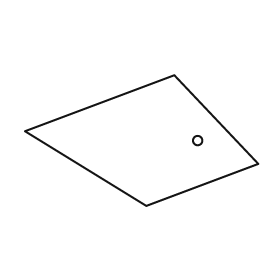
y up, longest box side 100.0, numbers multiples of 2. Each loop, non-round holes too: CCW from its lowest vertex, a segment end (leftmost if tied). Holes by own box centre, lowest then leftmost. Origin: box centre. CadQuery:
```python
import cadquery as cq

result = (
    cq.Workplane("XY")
    .moveTo(2.0, -28.0)
    .lineTo(50.0, -10.0)
    .lineTo(14.0, 28.0)
    .lineTo(-50.0, 4.0)
    .close()
    .moveTo(24.0, 0.0)
    .circle(2.0)
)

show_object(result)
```